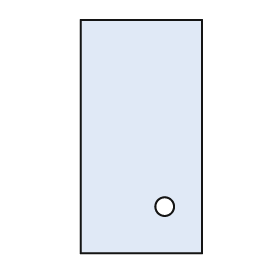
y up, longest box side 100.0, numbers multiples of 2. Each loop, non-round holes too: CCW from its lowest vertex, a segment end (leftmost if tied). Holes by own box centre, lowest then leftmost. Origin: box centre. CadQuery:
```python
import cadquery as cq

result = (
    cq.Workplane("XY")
    .moveTo(-26.0, -50.0)
    .lineTo(26.0, -50.0)
    .lineTo(26.0, 50.0)
    .lineTo(-26.0, 50.0)
    .close()
    .moveTo(10.0, -30.0)
    .circle(4.0)
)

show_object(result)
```